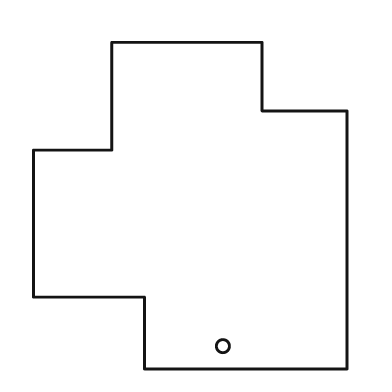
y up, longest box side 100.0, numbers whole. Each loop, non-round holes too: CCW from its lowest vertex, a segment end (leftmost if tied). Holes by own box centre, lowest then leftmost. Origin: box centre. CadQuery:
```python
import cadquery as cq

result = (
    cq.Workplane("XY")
    .moveTo(-14.0, -50.0)
    .lineTo(48.0, -50.0)
    .lineTo(48.0, 29.0)
    .lineTo(22.0, 29.0)
    .lineTo(22.0, 50.0)
    .lineTo(-24.0, 50.0)
    .lineTo(-24.0, 17.0)
    .lineTo(-48.0, 17.0)
    .lineTo(-48.0, -28.0)
    .lineTo(-14.0, -28.0)
    .close()
    .moveTo(10.0, -43.0)
    .circle(2.0)
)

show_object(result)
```